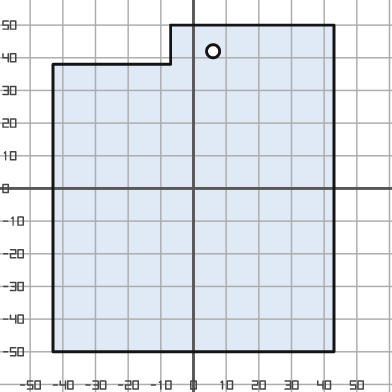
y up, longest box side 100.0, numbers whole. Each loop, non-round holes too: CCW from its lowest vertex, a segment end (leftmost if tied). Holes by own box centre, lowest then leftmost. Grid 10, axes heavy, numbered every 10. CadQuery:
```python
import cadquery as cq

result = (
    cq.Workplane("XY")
    .moveTo(-43.0, -50.0)
    .lineTo(43.0, -50.0)
    .lineTo(43.0, 50.0)
    .lineTo(-7.0, 50.0)
    .lineTo(-7.0, 38.0)
    .lineTo(-43.0, 38.0)
    .close()
    .moveTo(6.0, 42.0)
    .circle(2.0)
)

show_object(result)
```